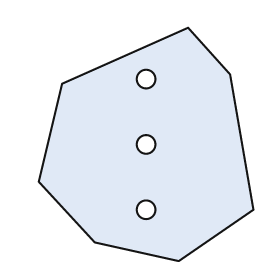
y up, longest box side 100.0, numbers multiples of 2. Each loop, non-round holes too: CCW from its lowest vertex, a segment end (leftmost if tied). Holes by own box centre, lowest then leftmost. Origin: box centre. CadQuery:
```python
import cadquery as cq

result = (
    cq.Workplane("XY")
    .moveTo(14.0, -50.0)
    .lineTo(46.0, -28.0)
    .lineTo(36.0, 30.0)
    .lineTo(18.0, 50.0)
    .lineTo(-36.0, 26.0)
    .lineTo(-46.0, -16.0)
    .lineTo(-22.0, -42.0)
    .close()
    .moveTo(0.0, -28.0)
    .circle(4.0)
    .moveTo(0.0, 0.0)
    .circle(4.0)
    .moveTo(0.0, 28.0)
    .circle(4.0)
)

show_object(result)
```